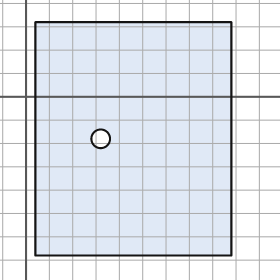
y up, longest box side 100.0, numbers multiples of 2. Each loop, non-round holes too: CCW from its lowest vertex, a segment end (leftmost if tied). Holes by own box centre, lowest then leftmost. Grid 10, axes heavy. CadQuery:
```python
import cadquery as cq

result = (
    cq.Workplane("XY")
    .moveTo(4.0, -68.0)
    .lineTo(88.0, -68.0)
    .lineTo(88.0, 32.0)
    .lineTo(4.0, 32.0)
    .close()
    .moveTo(32.0, -18.0)
    .circle(4.0)
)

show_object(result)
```